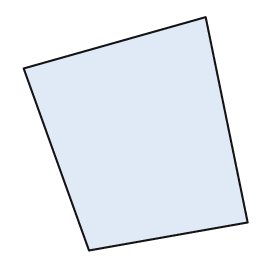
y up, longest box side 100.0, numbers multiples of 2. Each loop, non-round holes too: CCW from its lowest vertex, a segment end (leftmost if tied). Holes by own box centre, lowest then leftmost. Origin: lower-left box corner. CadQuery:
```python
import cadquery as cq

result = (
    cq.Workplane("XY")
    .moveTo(28.0, 0.0)
    .lineTo(96.0, 12.0)
    .lineTo(78.0, 100.0)
    .lineTo(0.0, 78.0)
    .close()
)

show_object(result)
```